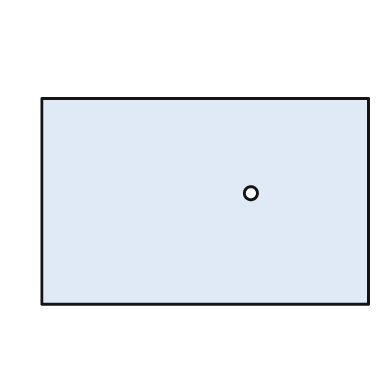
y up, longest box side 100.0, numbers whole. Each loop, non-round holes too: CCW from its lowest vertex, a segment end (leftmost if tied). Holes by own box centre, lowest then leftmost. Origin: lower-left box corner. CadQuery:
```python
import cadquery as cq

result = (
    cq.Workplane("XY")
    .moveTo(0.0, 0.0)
    .lineTo(100.0, 0.0)
    .lineTo(100.0, 63.0)
    .lineTo(0.0, 63.0)
    .close()
    .moveTo(64.0, 34.0)
    .circle(2.0)
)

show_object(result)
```